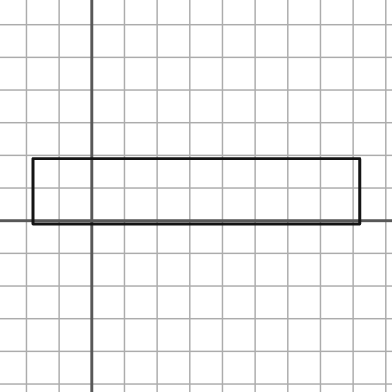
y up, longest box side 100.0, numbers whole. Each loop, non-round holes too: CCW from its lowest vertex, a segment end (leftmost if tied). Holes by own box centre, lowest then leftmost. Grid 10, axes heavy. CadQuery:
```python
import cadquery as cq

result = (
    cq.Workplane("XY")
    .moveTo(-18.0, -1.0)
    .lineTo(82.0, -1.0)
    .lineTo(82.0, 19.0)
    .lineTo(-18.0, 19.0)
    .close()
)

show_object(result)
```